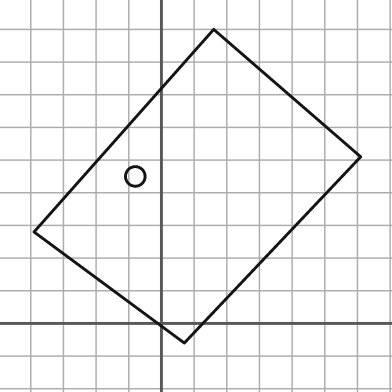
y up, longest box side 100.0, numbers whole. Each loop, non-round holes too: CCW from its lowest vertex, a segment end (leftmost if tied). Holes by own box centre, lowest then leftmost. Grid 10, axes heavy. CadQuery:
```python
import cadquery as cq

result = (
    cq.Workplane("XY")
    .moveTo(7.0, -6.0)
    .lineTo(61.0, 51.0)
    .lineTo(16.0, 90.0)
    .lineTo(-39.0, 28.0)
    .close()
    .moveTo(-8.0, 45.0)
    .circle(3.0)
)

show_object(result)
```